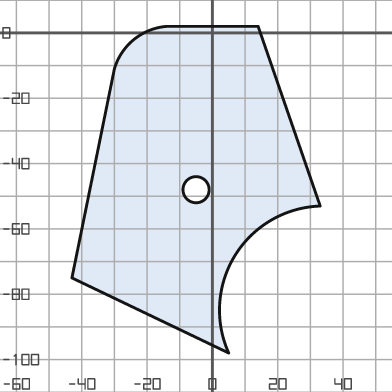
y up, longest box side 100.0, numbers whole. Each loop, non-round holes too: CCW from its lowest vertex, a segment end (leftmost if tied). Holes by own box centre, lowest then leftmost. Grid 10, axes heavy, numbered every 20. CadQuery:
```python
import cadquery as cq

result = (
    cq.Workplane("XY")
    .moveTo(5.0, -98.0)
    .threePointArc((7.0, -68.0), (33.0, -53.0))
    .lineTo(14.0, 2.0)
    .lineTo(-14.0, 2.0)
    .threePointArc((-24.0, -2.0), (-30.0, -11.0))
    .lineTo(-43.0, -75.0)
    .close()
    .moveTo(-5.0, -48.0)
    .circle(4.0)
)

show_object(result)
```